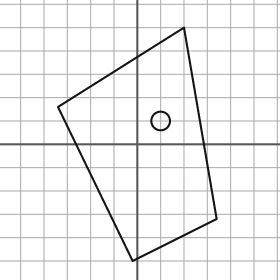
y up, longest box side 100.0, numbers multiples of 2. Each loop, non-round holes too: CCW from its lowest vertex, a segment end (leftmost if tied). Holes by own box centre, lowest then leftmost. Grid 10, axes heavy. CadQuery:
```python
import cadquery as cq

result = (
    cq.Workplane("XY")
    .moveTo(-2.0, -50.0)
    .lineTo(34.0, -32.0)
    .lineTo(20.0, 50.0)
    .lineTo(-34.0, 16.0)
    .close()
    .moveTo(10.0, 10.0)
    .circle(4.0)
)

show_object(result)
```